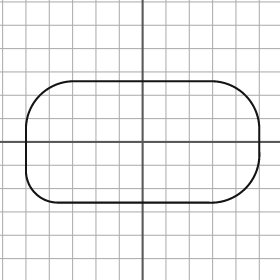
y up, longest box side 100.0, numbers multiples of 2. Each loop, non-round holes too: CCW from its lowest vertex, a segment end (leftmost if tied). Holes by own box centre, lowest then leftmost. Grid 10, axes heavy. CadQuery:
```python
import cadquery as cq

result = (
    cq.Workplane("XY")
    .moveTo(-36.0, -26.0)
    .lineTo(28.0, -26.0)
    .threePointArc((44.0, -20.0), (50.0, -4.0))
    .lineTo(50.0, 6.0)
    .threePointArc((44.0, 20.0), (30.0, 26.0))
    .lineTo(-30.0, 26.0)
    .threePointArc((-44.0, 20.0), (-50.0, 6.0))
    .lineTo(-50.0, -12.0)
    .threePointArc((-46.0, -22.0), (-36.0, -26.0))
    .close()
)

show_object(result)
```